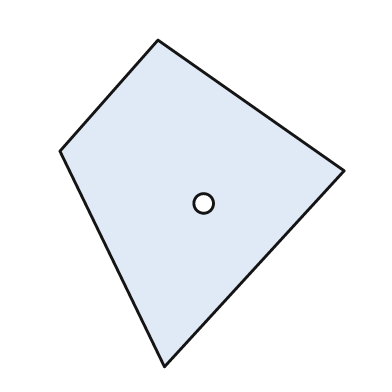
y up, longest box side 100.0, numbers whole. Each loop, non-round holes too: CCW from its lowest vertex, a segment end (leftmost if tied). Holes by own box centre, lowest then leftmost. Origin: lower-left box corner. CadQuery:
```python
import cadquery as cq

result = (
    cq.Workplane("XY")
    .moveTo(32.0, 0.0)
    .lineTo(87.0, 60.0)
    .lineTo(30.0, 100.0)
    .lineTo(0.0, 66.0)
    .close()
    .moveTo(44.0, 50.0)
    .circle(3.0)
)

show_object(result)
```